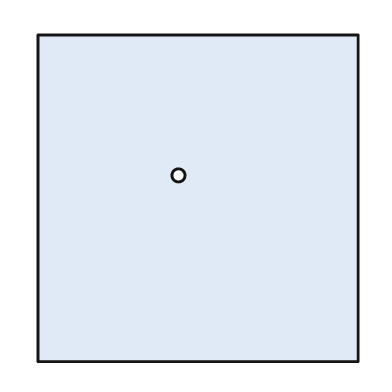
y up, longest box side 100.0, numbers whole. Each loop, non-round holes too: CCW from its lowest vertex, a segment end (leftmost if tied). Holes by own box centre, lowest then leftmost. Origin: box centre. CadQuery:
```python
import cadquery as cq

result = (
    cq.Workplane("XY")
    .moveTo(-49.0, -50.0)
    .lineTo(49.0, -50.0)
    .lineTo(49.0, 50.0)
    .lineTo(-49.0, 50.0)
    .close()
    .moveTo(-6.0, 7.0)
    .circle(2.0)
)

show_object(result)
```